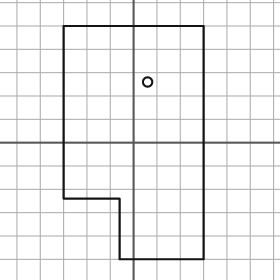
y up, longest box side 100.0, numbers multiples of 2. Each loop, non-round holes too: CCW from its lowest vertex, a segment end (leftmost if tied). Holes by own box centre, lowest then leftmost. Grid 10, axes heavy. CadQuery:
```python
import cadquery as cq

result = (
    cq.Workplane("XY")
    .moveTo(-6.0, -50.0)
    .lineTo(30.0, -50.0)
    .lineTo(30.0, 50.0)
    .lineTo(-30.0, 50.0)
    .lineTo(-30.0, -24.0)
    .lineTo(-6.0, -24.0)
    .close()
    .moveTo(6.0, 26.0)
    .circle(2.0)
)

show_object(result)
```